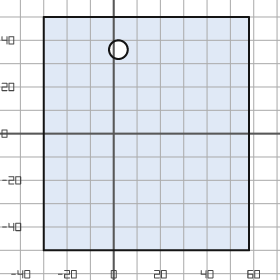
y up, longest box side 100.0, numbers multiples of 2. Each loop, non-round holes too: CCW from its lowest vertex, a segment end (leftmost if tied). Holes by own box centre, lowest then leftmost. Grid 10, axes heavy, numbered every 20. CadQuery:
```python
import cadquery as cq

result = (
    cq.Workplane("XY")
    .moveTo(-30.0, -50.0)
    .lineTo(58.0, -50.0)
    .lineTo(58.0, 50.0)
    .lineTo(-30.0, 50.0)
    .close()
    .moveTo(2.0, 36.0)
    .circle(4.0)
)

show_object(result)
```